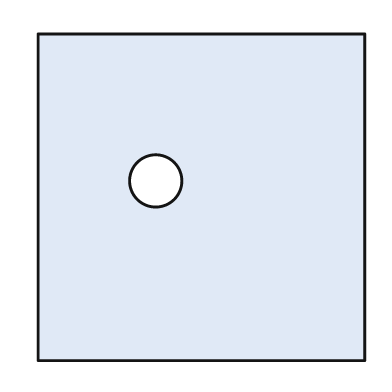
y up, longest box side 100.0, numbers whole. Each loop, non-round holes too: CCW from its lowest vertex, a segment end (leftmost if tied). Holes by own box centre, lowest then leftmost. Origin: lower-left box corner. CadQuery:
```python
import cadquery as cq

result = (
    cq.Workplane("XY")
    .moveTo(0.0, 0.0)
    .lineTo(100.0, 0.0)
    .lineTo(100.0, 100.0)
    .lineTo(0.0, 100.0)
    .close()
    .moveTo(36.0, 55.0)
    .circle(8.0)
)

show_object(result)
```